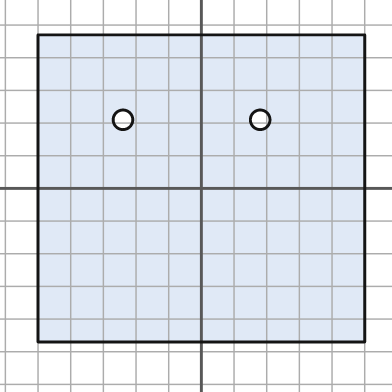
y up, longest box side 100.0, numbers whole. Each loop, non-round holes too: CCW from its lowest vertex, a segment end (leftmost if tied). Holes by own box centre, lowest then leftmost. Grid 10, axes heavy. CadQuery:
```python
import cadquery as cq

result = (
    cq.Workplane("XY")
    .moveTo(-50.0, -47.0)
    .lineTo(50.0, -47.0)
    .lineTo(50.0, 47.0)
    .lineTo(-50.0, 47.0)
    .close()
    .moveTo(-24.0, 21.0)
    .circle(3.0)
    .moveTo(18.0, 21.0)
    .circle(3.0)
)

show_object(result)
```